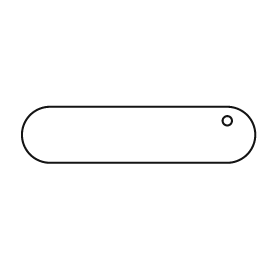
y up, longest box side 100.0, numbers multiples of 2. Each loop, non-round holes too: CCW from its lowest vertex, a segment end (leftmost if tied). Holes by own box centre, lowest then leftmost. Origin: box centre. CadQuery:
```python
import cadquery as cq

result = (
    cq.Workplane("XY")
    .moveTo(-38.0, -12.0)
    .lineTo(38.0, -12.0)
    .threePointArc((50.0, 0.0), (38.0, 12.0))
    .lineTo(-38.0, 12.0)
    .threePointArc((-50.0, 0.0), (-38.0, -12.0))
    .close()
    .moveTo(38.0, 6.0)
    .circle(2.0)
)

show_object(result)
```